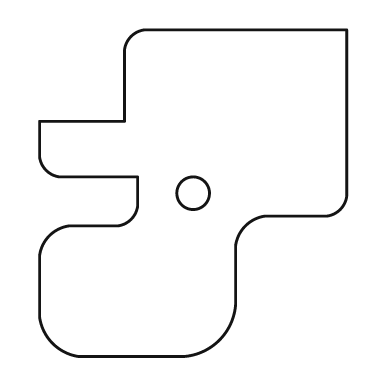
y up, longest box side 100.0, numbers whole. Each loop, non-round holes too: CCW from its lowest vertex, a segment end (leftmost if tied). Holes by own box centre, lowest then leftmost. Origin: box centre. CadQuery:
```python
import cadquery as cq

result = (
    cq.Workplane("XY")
    .moveTo(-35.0, -50.0)
    .lineTo(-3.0, -50.0)
    .threePointArc((8.0, -45.0), (13.0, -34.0))
    .lineTo(13.0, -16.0)
    .threePointArc((16.0, -10.0), (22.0, -7.0))
    .lineTo(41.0, -7.0)
    .threePointArc((45.0, -5.0), (47.0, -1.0))
    .lineTo(47.0, 50.0)
    .lineTo(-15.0, 50.0)
    .threePointArc((-19.0, 48.0), (-21.0, 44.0))
    .lineTo(-21.0, 22.0)
    .lineTo(-47.0, 22.0)
    .lineTo(-47.0, 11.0)
    .threePointArc((-45.0, 7.0), (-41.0, 5.0))
    .lineTo(-17.0, 5.0)
    .lineTo(-17.0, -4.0)
    .threePointArc((-19.0, -8.0), (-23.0, -10.0))
    .lineTo(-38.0, -10.0)
    .threePointArc((-44.0, -13.0), (-47.0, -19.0))
    .lineTo(-47.0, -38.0)
    .threePointArc((-43.0, -46.0), (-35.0, -50.0))
    .close()
    .moveTo(0.0, 0.0)
    .circle(5.0)
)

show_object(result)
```